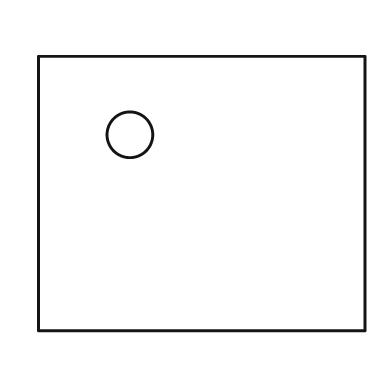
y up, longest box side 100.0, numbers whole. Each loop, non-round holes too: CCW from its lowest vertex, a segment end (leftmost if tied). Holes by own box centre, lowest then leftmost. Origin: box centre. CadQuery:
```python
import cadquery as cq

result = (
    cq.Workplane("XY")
    .moveTo(-50.0, -42.0)
    .lineTo(50.0, -42.0)
    .lineTo(50.0, 42.0)
    .lineTo(-50.0, 42.0)
    .close()
    .moveTo(-22.0, 18.0)
    .circle(7.0)
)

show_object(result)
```